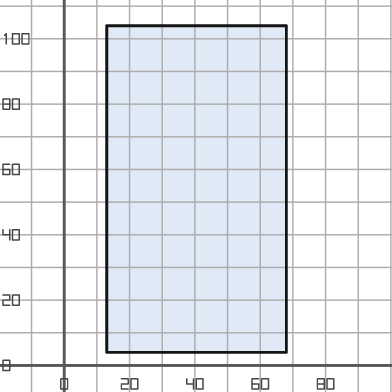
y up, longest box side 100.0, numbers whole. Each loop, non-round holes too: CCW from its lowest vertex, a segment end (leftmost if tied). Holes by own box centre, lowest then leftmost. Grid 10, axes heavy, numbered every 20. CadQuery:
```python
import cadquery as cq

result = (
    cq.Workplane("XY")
    .moveTo(13.0, 4.0)
    .lineTo(68.0, 4.0)
    .lineTo(68.0, 104.0)
    .lineTo(13.0, 104.0)
    .close()
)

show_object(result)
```